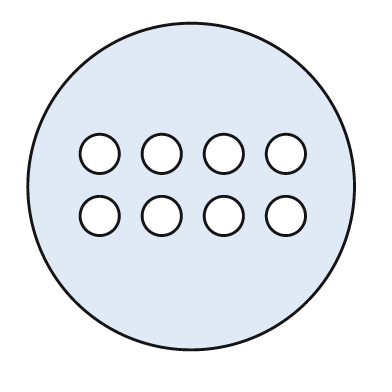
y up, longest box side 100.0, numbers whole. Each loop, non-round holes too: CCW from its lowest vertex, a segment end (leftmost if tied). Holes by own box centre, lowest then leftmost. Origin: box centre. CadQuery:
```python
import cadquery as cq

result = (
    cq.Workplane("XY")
    .moveTo(0.0, 0.0)
    .circle(50.0)
    .moveTo(-28.0, -9.0)
    .circle(6.0)
    .moveTo(-9.0, -9.0)
    .circle(6.0)
    .moveTo(10.0, -9.0)
    .circle(6.0)
    .moveTo(29.0, -9.0)
    .circle(6.0)
    .moveTo(-28.0, 10.0)
    .circle(6.0)
    .moveTo(-9.0, 10.0)
    .circle(6.0)
    .moveTo(10.0, 10.0)
    .circle(6.0)
    .moveTo(29.0, 10.0)
    .circle(6.0)
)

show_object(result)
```